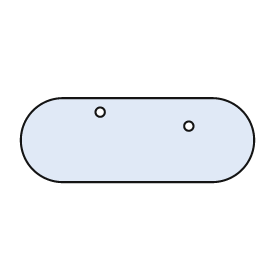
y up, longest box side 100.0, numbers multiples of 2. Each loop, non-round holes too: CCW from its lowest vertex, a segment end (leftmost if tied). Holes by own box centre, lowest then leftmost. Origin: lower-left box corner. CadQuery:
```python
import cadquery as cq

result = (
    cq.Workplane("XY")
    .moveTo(18.0, 0.0)
    .lineTo(82.0, 0.0)
    .threePointArc((100.0, 18.0), (82.0, 36.0))
    .lineTo(18.0, 36.0)
    .threePointArc((0.0, 18.0), (18.0, 0.0))
    .close()
    .moveTo(72.0, 24.0)
    .circle(2.0)
    .moveTo(34.0, 30.0)
    .circle(2.0)
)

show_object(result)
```